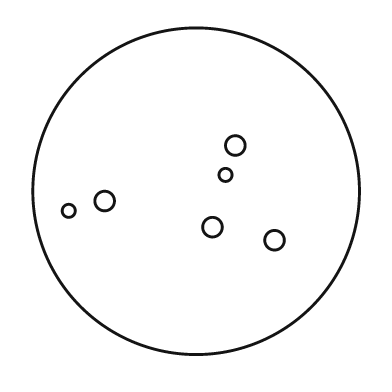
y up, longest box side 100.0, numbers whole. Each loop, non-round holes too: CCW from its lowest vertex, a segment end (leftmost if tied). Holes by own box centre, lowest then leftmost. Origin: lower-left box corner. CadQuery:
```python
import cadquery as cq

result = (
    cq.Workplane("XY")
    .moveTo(50.0, 50.0)
    .circle(50.0)
    .moveTo(74.0, 35.0)
    .circle(3.0)
    .moveTo(55.0, 39.0)
    .circle(3.0)
    .moveTo(11.0, 44.0)
    .circle(2.0)
    .moveTo(22.0, 47.0)
    .circle(3.0)
    .moveTo(59.0, 55.0)
    .circle(2.0)
    .moveTo(62.0, 64.0)
    .circle(3.0)
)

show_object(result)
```